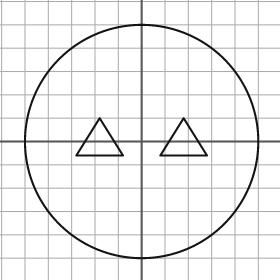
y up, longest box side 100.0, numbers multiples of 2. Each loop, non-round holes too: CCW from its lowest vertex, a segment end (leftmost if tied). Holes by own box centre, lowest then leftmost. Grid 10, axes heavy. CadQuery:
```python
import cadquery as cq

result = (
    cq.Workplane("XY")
    .moveTo(0.0, 0.0)
    .circle(50.0)
    .moveTo(-28.0, -6.0)
    .lineTo(-8.0, -6.0)
    .lineTo(-18.0, 10.0)
    .close()
    .moveTo(8.0, -6.0)
    .lineTo(28.0, -6.0)
    .lineTo(18.0, 10.0)
    .close()
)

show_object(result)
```